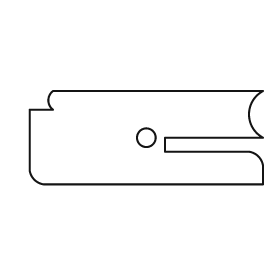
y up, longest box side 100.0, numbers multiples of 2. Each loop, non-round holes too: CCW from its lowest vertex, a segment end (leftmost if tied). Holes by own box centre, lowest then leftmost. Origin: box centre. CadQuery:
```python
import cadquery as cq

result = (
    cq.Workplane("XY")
    .moveTo(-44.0, -20.0)
    .lineTo(50.0, -20.0)
    .lineTo(50.0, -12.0)
    .threePointArc((48.0, -8.0), (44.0, -6.0))
    .lineTo(8.0, -6.0)
    .lineTo(8.0, 0.0)
    .lineTo(50.0, 0.0)
    .threePointArc((44.0, 10.0), (50.0, 20.0))
    .lineTo(-40.0, 20.0)
    .threePointArc((-42.0, 16.0), (-40.0, 12.0))
    .lineTo(-50.0, 12.0)
    .lineTo(-50.0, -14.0)
    .threePointArc((-48.0, -18.0), (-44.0, -20.0))
    .close()
    .moveTo(0.0, 0.0)
    .circle(4.0)
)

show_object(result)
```